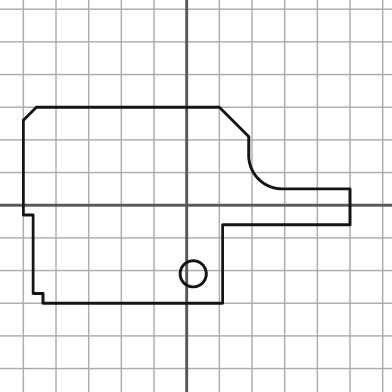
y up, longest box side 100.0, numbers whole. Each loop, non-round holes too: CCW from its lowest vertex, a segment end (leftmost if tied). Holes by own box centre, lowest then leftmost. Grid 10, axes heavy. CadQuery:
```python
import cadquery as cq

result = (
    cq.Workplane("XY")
    .moveTo(-44.0, -30.0)
    .lineTo(11.0, -30.0)
    .lineTo(11.0, -6.0)
    .lineTo(50.0, -6.0)
    .lineTo(50.0, 5.0)
    .lineTo(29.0, 5.0)
    .threePointArc((22.0, 8.0), (19.0, 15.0))
    .lineTo(19.0, 21.0)
    .lineTo(10.0, 30.0)
    .lineTo(-46.0, 30.0)
    .lineTo(-50.0, 26.0)
    .lineTo(-50.0, -3.0)
    .lineTo(-47.0, -3.0)
    .lineTo(-47.0, -27.0)
    .lineTo(-44.0, -27.0)
    .close()
    .moveTo(2.0, -21.0)
    .circle(4.0)
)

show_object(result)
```